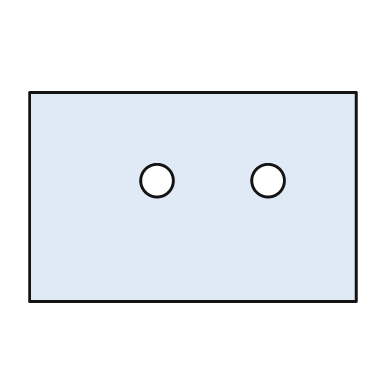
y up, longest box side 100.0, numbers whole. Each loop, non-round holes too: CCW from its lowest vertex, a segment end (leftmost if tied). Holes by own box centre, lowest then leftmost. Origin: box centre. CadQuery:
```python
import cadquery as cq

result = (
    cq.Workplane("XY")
    .moveTo(-50.0, -32.0)
    .lineTo(50.0, -32.0)
    .lineTo(50.0, 32.0)
    .lineTo(-50.0, 32.0)
    .close()
    .moveTo(-11.0, 5.0)
    .circle(5.0)
    .moveTo(23.0, 5.0)
    .circle(5.0)
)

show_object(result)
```